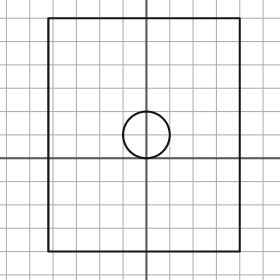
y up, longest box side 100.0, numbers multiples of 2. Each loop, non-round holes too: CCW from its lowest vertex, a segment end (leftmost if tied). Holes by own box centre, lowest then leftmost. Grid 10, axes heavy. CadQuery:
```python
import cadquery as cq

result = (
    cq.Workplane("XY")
    .moveTo(-42.0, -40.0)
    .lineTo(40.0, -40.0)
    .lineTo(40.0, 60.0)
    .lineTo(-42.0, 60.0)
    .close()
    .moveTo(0.0, 10.0)
    .circle(10.0)
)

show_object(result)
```